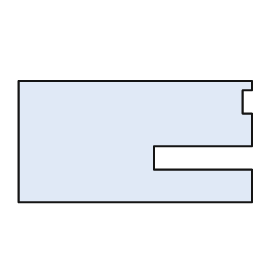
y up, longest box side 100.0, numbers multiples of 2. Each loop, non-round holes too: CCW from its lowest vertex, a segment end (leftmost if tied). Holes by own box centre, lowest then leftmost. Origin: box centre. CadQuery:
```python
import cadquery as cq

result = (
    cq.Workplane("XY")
    .moveTo(-50.0, -26.0)
    .lineTo(50.0, -26.0)
    .lineTo(50.0, -12.0)
    .lineTo(8.0, -12.0)
    .lineTo(8.0, -2.0)
    .lineTo(50.0, -2.0)
    .lineTo(50.0, 12.0)
    .lineTo(46.0, 12.0)
    .lineTo(46.0, 22.0)
    .lineTo(50.0, 22.0)
    .lineTo(50.0, 26.0)
    .lineTo(-50.0, 26.0)
    .close()
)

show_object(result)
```